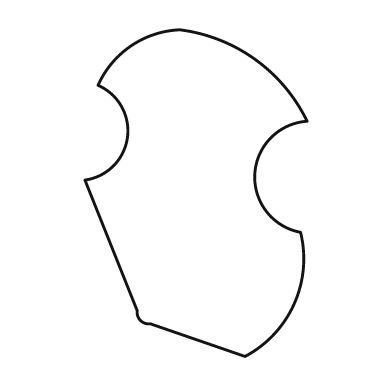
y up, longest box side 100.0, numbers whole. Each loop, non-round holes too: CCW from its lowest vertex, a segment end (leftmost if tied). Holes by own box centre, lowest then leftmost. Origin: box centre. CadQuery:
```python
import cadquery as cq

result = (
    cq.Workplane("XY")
    .moveTo(15.0, -50.0)
    .threePointArc((30.0, -34.0), (32.0, -12.0))
    .threePointArc((18.0, 6.0), (34.0, 22.0))
    .threePointArc((18.0, 41.0), (-5.0, 50.0))
    .threePointArc((-20.0, 45.0), (-30.0, 33.0))
    .threePointArc((-21.0, 17.0), (-34.0, 4.0))
    .lineTo(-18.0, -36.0)
    .threePointArc((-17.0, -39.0), (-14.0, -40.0))
    .close()
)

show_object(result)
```